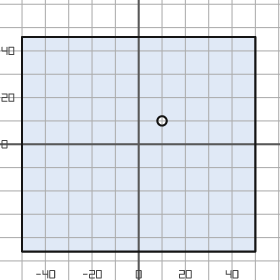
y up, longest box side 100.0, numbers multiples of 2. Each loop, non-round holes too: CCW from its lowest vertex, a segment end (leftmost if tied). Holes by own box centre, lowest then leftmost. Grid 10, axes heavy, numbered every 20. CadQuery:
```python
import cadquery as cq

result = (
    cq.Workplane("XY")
    .moveTo(-50.0, -46.0)
    .lineTo(50.0, -46.0)
    .lineTo(50.0, 46.0)
    .lineTo(-50.0, 46.0)
    .close()
    .moveTo(10.0, 10.0)
    .circle(2.0)
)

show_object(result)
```